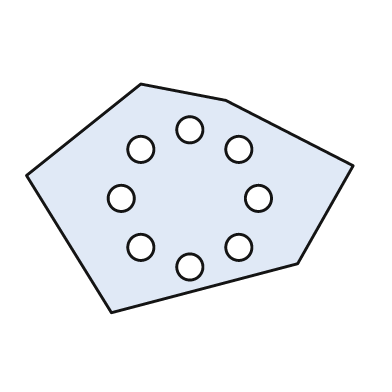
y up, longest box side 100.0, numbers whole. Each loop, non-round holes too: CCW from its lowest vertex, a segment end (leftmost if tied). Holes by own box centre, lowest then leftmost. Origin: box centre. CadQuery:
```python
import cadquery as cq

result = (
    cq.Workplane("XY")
    .moveTo(-24.0, -35.0)
    .lineTo(33.0, -20.0)
    .lineTo(50.0, 10.0)
    .lineTo(11.0, 30.0)
    .lineTo(-15.0, 35.0)
    .lineTo(-50.0, 7.0)
    .close()
    .moveTo(0.0, -21.0)
    .circle(4.0)
    .moveTo(-15.0, -15.0)
    .circle(4.0)
    .moveTo(15.0, -15.0)
    .circle(4.0)
    .moveTo(-21.0, 0.0)
    .circle(4.0)
    .moveTo(21.0, 0.0)
    .circle(4.0)
    .moveTo(-15.0, 15.0)
    .circle(4.0)
    .moveTo(15.0, 15.0)
    .circle(4.0)
    .moveTo(0.0, 21.0)
    .circle(4.0)
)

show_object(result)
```